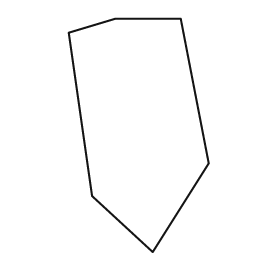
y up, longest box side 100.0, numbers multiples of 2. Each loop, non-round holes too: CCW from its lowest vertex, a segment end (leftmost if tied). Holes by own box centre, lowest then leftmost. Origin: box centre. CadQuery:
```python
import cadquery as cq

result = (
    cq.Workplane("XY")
    .moveTo(6.0, -50.0)
    .lineTo(30.0, -12.0)
    .lineTo(18.0, 50.0)
    .lineTo(-10.0, 50.0)
    .lineTo(-30.0, 44.0)
    .lineTo(-20.0, -26.0)
    .close()
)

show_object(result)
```